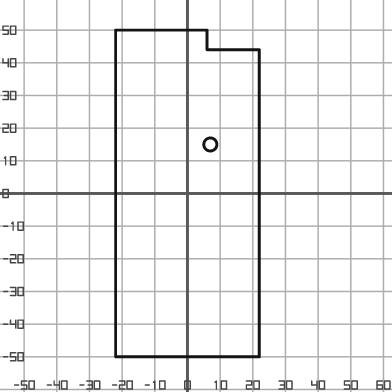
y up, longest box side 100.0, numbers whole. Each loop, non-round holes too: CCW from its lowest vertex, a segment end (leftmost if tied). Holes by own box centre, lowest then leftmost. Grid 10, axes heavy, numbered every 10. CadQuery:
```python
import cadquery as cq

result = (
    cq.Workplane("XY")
    .moveTo(-22.0, -50.0)
    .lineTo(22.0, -50.0)
    .lineTo(22.0, 44.0)
    .lineTo(6.0, 44.0)
    .lineTo(6.0, 50.0)
    .lineTo(-22.0, 50.0)
    .close()
    .moveTo(7.0, 15.0)
    .circle(2.0)
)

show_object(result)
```